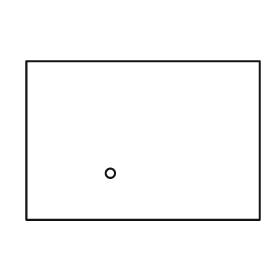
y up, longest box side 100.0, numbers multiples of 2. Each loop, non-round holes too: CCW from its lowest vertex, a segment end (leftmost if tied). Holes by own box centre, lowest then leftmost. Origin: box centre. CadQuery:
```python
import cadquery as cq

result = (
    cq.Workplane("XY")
    .moveTo(-50.0, -34.0)
    .lineTo(50.0, -34.0)
    .lineTo(50.0, 34.0)
    .lineTo(-50.0, 34.0)
    .close()
    .moveTo(-14.0, -14.0)
    .circle(2.0)
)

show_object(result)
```